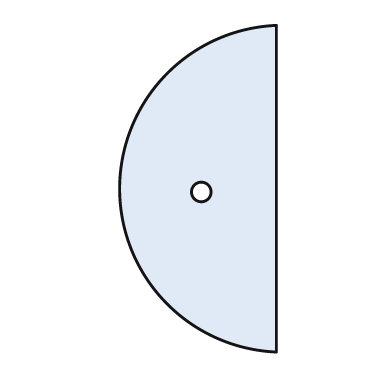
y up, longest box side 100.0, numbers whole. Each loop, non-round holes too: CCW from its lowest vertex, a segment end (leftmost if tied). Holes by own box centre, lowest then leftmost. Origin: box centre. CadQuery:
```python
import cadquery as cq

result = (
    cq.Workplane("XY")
    .moveTo(24.0, -50.0)
    .lineTo(24.0, 50.0)
    .threePointArc((-24.0, 0.0), (24.0, -50.0))
    .close()
    .moveTo(1.0, -1.0)
    .circle(3.0)
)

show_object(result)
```